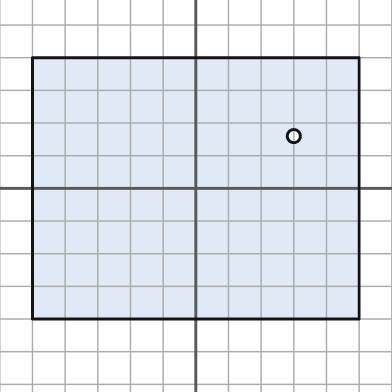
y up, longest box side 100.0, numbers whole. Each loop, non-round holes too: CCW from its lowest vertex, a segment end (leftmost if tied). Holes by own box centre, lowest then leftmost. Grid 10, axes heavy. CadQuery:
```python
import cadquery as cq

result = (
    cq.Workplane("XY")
    .moveTo(-50.0, -40.0)
    .lineTo(50.0, -40.0)
    .lineTo(50.0, 40.0)
    .lineTo(-50.0, 40.0)
    .close()
    .moveTo(30.0, 16.0)
    .circle(2.0)
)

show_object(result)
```